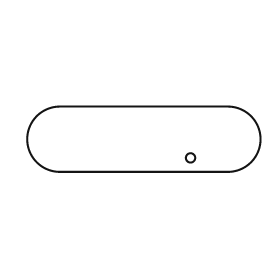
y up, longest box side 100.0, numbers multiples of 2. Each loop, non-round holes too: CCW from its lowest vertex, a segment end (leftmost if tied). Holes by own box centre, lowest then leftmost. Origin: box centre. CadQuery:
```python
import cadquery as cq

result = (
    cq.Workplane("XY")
    .moveTo(-36.0, -14.0)
    .lineTo(36.0, -14.0)
    .threePointArc((50.0, 0.0), (36.0, 14.0))
    .lineTo(-36.0, 14.0)
    .threePointArc((-50.0, 0.0), (-36.0, -14.0))
    .close()
    .moveTo(20.0, -8.0)
    .circle(2.0)
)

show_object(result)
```